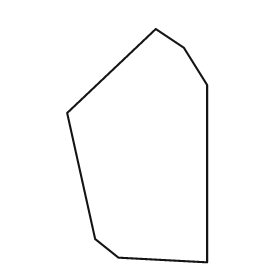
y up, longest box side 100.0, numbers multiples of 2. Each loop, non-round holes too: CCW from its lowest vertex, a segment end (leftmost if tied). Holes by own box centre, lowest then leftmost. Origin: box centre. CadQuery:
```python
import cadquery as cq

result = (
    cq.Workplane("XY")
    .moveTo(30.0, -50.0)
    .lineTo(30.0, 26.0)
    .lineTo(20.0, 42.0)
    .lineTo(8.0, 50.0)
    .lineTo(-30.0, 14.0)
    .lineTo(-18.0, -40.0)
    .lineTo(-8.0, -48.0)
    .close()
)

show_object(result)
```